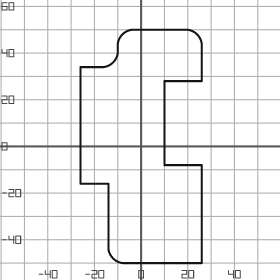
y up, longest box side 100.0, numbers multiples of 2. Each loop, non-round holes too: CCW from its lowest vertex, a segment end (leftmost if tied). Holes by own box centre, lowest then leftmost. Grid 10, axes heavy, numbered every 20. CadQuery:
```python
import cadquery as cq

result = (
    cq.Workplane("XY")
    .moveTo(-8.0, -50.0)
    .lineTo(26.0, -50.0)
    .lineTo(26.0, -8.0)
    .lineTo(10.0, -8.0)
    .lineTo(10.0, 28.0)
    .lineTo(26.0, 28.0)
    .lineTo(26.0, 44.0)
    .threePointArc((24.0, 48.0), (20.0, 50.0))
    .lineTo(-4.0, 50.0)
    .threePointArc((-8.0, 48.0), (-10.0, 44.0))
    .lineTo(-10.0, 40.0)
    .threePointArc((-12.0, 36.0), (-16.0, 34.0))
    .lineTo(-26.0, 34.0)
    .lineTo(-26.0, -16.0)
    .lineTo(-14.0, -16.0)
    .lineTo(-14.0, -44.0)
    .threePointArc((-12.0, -48.0), (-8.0, -50.0))
    .close()
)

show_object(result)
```